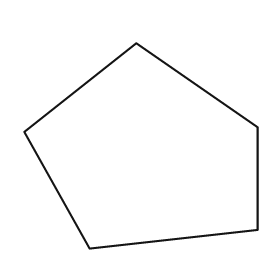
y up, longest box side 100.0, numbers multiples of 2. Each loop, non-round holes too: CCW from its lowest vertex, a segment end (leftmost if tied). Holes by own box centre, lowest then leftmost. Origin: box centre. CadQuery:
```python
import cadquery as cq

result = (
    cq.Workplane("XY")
    .moveTo(-22.0, -44.0)
    .lineTo(50.0, -36.0)
    .lineTo(50.0, 8.0)
    .lineTo(-2.0, 44.0)
    .lineTo(-50.0, 6.0)
    .close()
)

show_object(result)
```